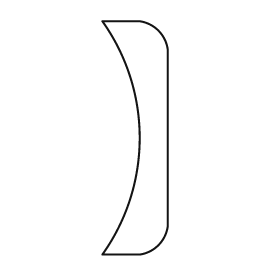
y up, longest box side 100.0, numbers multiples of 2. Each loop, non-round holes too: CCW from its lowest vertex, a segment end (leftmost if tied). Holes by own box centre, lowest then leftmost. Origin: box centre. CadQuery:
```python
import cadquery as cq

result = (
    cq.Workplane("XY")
    .moveTo(-14.0, -50.0)
    .lineTo(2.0, -50.0)
    .threePointArc((10.0, -46.0), (14.0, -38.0))
    .lineTo(14.0, 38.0)
    .threePointArc((10.0, 46.0), (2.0, 50.0))
    .lineTo(-14.0, 50.0)
    .threePointArc((2.0, 0.0), (-14.0, -50.0))
    .close()
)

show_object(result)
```